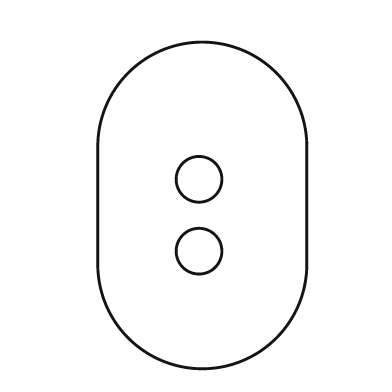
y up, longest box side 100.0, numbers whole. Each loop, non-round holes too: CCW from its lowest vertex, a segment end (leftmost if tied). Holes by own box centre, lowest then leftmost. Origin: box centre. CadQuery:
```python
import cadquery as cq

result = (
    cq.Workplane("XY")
    .moveTo(-32.0, -18.0)
    .threePointArc((0.0, -50.0), (32.0, -18.0))
    .lineTo(32.0, 18.0)
    .threePointArc((0.0, 50.0), (-32.0, 18.0))
    .close()
    .moveTo(-1.0, -14.0)
    .circle(7.0)
    .moveTo(-1.0, 8.0)
    .circle(7.0)
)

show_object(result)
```